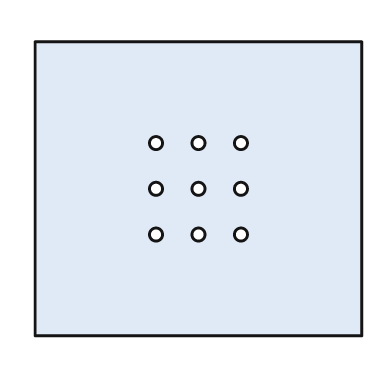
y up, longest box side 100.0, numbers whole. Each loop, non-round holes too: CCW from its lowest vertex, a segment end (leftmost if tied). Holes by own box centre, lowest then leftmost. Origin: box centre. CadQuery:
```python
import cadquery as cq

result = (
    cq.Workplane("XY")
    .moveTo(-50.0, -45.0)
    .lineTo(50.0, -45.0)
    .lineTo(50.0, 45.0)
    .lineTo(-50.0, 45.0)
    .close()
    .moveTo(-13.0, -14.0)
    .circle(2.0)
    .moveTo(0.0, -14.0)
    .circle(2.0)
    .moveTo(13.0, -14.0)
    .circle(2.0)
    .moveTo(-13.0, 0.0)
    .circle(2.0)
    .moveTo(0.0, 0.0)
    .circle(2.0)
    .moveTo(13.0, 0.0)
    .circle(2.0)
    .moveTo(-13.0, 14.0)
    .circle(2.0)
    .moveTo(0.0, 14.0)
    .circle(2.0)
    .moveTo(13.0, 14.0)
    .circle(2.0)
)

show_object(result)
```